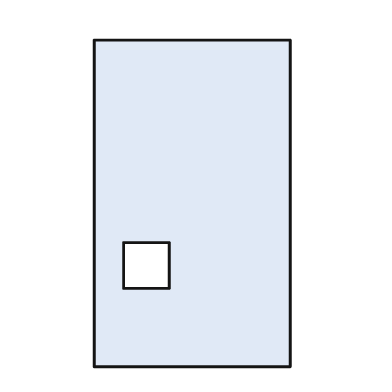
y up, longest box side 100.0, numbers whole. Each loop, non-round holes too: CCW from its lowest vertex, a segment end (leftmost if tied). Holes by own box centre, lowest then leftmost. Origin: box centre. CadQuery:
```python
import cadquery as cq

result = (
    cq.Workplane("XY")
    .moveTo(-30.0, -50.0)
    .lineTo(30.0, -50.0)
    .lineTo(30.0, 50.0)
    .lineTo(-30.0, 50.0)
    .close()
    .moveTo(-21.0, -26.0)
    .lineTo(-7.0, -26.0)
    .lineTo(-7.0, -12.0)
    .lineTo(-21.0, -12.0)
    .close()
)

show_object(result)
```